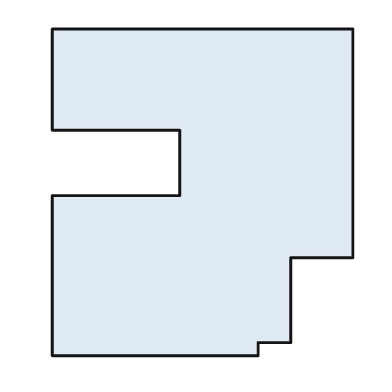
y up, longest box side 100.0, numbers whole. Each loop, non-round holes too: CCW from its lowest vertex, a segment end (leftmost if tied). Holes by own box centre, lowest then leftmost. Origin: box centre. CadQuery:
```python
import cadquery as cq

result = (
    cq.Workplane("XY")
    .moveTo(-46.0, -50.0)
    .lineTo(17.0, -50.0)
    .lineTo(17.0, -46.0)
    .lineTo(27.0, -46.0)
    .lineTo(27.0, -20.0)
    .lineTo(46.0, -20.0)
    .lineTo(46.0, 50.0)
    .lineTo(-46.0, 50.0)
    .lineTo(-46.0, 19.0)
    .lineTo(-7.0, 19.0)
    .lineTo(-7.0, -1.0)
    .lineTo(-46.0, -1.0)
    .close()
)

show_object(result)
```